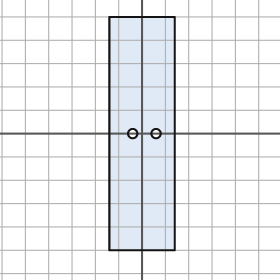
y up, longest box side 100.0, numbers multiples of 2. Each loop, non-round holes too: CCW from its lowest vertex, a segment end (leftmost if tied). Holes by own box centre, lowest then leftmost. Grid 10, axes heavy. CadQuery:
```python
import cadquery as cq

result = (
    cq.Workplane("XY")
    .moveTo(-14.0, -50.0)
    .lineTo(14.0, -50.0)
    .lineTo(14.0, 50.0)
    .lineTo(-14.0, 50.0)
    .close()
    .moveTo(-4.0, 0.0)
    .circle(2.0)
    .moveTo(6.0, 0.0)
    .circle(2.0)
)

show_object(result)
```